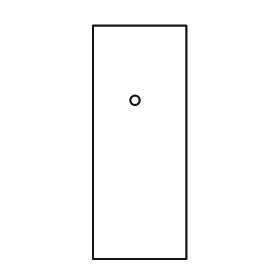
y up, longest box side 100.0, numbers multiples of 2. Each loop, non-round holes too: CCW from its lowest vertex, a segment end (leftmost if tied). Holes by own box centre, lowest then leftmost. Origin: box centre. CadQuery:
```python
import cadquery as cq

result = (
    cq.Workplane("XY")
    .moveTo(-20.0, -50.0)
    .lineTo(20.0, -50.0)
    .lineTo(20.0, 50.0)
    .lineTo(-20.0, 50.0)
    .close()
    .moveTo(-2.0, 18.0)
    .circle(2.0)
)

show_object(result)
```